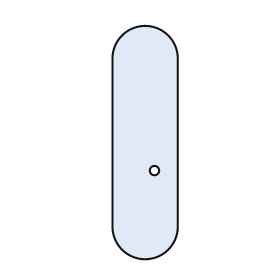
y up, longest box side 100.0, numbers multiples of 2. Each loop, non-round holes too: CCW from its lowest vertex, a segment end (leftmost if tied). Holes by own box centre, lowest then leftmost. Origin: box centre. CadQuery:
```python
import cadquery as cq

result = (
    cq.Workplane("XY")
    .moveTo(-14.0, -36.0)
    .threePointArc((0.0, -50.0), (14.0, -36.0))
    .lineTo(14.0, 36.0)
    .threePointArc((0.0, 50.0), (-14.0, 36.0))
    .close()
    .moveTo(4.0, -12.0)
    .circle(2.0)
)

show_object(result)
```